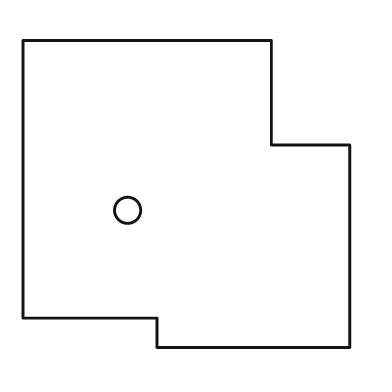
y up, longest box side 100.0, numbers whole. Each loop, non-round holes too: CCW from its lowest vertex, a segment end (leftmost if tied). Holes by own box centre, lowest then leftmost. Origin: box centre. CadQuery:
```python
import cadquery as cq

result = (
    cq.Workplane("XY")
    .moveTo(-9.0, -47.0)
    .lineTo(50.0, -47.0)
    .lineTo(50.0, 15.0)
    .lineTo(26.0, 15.0)
    .lineTo(26.0, 47.0)
    .lineTo(-50.0, 47.0)
    .lineTo(-50.0, -38.0)
    .lineTo(-9.0, -38.0)
    .close()
    .moveTo(-18.0, -5.0)
    .circle(4.0)
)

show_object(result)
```